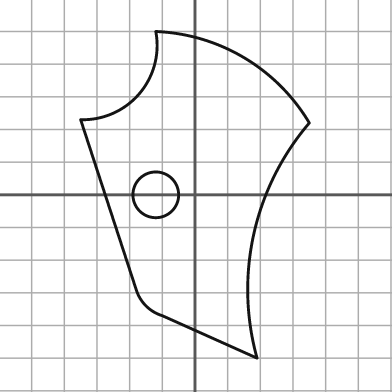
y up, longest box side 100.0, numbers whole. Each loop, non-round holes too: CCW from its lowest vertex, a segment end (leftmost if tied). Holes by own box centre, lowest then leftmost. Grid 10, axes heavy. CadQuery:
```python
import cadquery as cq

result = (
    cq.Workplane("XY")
    .moveTo(19.0, -50.0)
    .threePointArc((18.0, -12.0), (35.0, 22.0))
    .threePointArc((15.0, 42.0), (-12.0, 50.0))
    .threePointArc((-17.0, 31.0), (-35.0, 23.0))
    .lineTo(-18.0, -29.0)
    .threePointArc((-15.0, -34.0), (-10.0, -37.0))
    .close()
    .moveTo(-12.0, 0.0)
    .circle(7.0)
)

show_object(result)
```